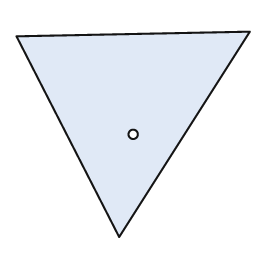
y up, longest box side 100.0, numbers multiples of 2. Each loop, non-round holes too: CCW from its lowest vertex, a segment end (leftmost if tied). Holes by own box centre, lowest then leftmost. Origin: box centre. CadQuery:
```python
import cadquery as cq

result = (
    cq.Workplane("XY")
    .moveTo(-6.0, -44.0)
    .lineTo(50.0, 44.0)
    .lineTo(-50.0, 42.0)
    .close()
    .moveTo(0.0, 0.0)
    .circle(2.0)
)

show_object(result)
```